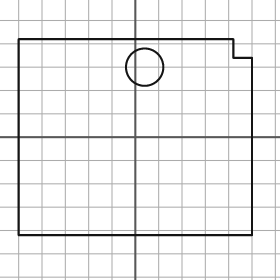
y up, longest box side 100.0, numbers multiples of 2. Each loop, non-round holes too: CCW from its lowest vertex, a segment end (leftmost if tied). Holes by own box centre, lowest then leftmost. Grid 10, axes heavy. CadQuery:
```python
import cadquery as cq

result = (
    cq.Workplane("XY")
    .moveTo(-50.0, -42.0)
    .lineTo(50.0, -42.0)
    .lineTo(50.0, 34.0)
    .lineTo(42.0, 34.0)
    .lineTo(42.0, 42.0)
    .lineTo(-50.0, 42.0)
    .close()
    .moveTo(4.0, 30.0)
    .circle(8.0)
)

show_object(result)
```